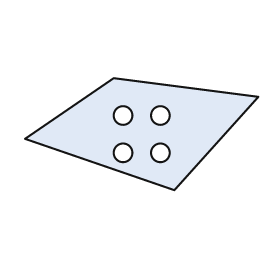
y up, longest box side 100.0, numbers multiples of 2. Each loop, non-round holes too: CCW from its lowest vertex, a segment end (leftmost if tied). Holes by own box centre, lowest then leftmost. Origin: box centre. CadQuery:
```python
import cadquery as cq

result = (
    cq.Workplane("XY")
    .moveTo(14.0, -24.0)
    .lineTo(50.0, 16.0)
    .lineTo(-12.0, 24.0)
    .lineTo(-50.0, -2.0)
    .close()
    .moveTo(-8.0, -8.0)
    .circle(4.0)
    .moveTo(8.0, -8.0)
    .circle(4.0)
    .moveTo(-8.0, 8.0)
    .circle(4.0)
    .moveTo(8.0, 8.0)
    .circle(4.0)
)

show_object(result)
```